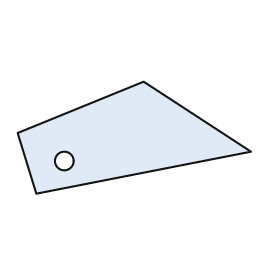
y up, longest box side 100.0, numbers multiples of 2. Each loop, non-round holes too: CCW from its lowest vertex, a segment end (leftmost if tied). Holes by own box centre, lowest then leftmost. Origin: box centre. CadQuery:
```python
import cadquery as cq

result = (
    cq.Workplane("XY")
    .moveTo(-42.0, -24.0)
    .lineTo(50.0, -6.0)
    .lineTo(4.0, 24.0)
    .lineTo(-50.0, 2.0)
    .close()
    .moveTo(-30.0, -10.0)
    .circle(4.0)
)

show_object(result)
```